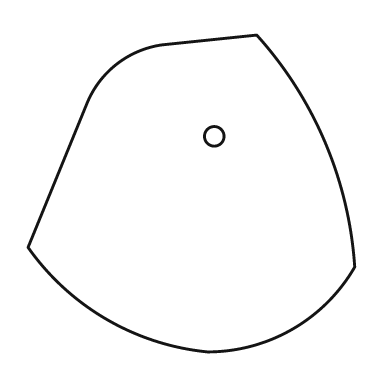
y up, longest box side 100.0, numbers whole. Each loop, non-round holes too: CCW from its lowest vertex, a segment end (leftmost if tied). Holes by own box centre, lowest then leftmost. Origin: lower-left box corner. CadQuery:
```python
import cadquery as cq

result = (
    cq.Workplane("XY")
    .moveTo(55.0, 0.0)
    .threePointArc((81.0, 7.0), (100.0, 26.0))
    .threePointArc((91.0, 64.0), (70.0, 97.0))
    .lineTo(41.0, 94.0)
    .threePointArc((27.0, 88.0), (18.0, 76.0))
    .lineTo(0.0, 32.0)
    .threePointArc((24.0, 10.0), (55.0, 0.0))
    .close()
    .moveTo(57.0, 66.0)
    .circle(3.0)
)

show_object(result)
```